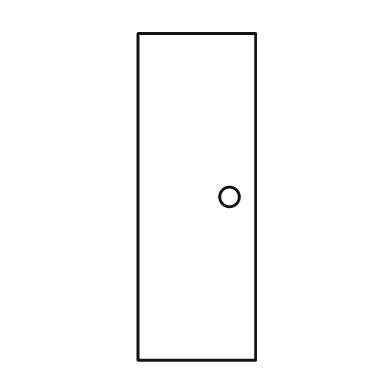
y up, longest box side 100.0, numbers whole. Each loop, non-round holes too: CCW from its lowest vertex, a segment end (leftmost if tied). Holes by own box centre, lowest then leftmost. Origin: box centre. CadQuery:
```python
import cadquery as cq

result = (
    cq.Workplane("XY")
    .moveTo(-18.0, -50.0)
    .lineTo(18.0, -50.0)
    .lineTo(18.0, 50.0)
    .lineTo(-18.0, 50.0)
    .close()
    .moveTo(10.0, 0.0)
    .circle(3.0)
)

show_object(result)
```